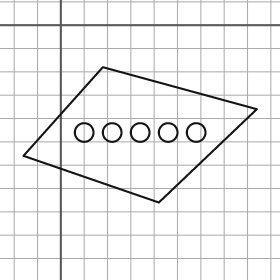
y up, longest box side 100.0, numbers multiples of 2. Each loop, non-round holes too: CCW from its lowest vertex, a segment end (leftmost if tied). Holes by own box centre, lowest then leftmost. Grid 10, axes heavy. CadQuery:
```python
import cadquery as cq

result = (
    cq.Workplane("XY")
    .moveTo(42.0, -76.0)
    .lineTo(84.0, -36.0)
    .lineTo(18.0, -18.0)
    .lineTo(-16.0, -56.0)
    .close()
    .moveTo(10.0, -46.0)
    .circle(4.0)
    .moveTo(22.0, -46.0)
    .circle(4.0)
    .moveTo(34.0, -46.0)
    .circle(4.0)
    .moveTo(46.0, -46.0)
    .circle(4.0)
    .moveTo(58.0, -46.0)
    .circle(4.0)
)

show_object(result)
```